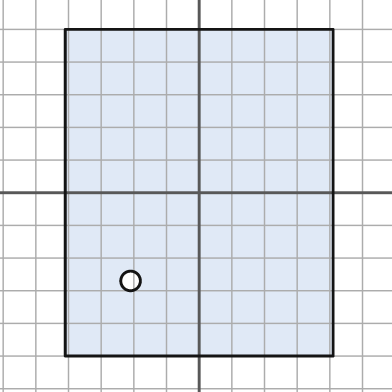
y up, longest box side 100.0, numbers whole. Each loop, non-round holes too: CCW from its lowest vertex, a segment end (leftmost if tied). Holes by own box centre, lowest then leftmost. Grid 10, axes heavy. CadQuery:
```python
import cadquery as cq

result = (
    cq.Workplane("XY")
    .moveTo(-41.0, -50.0)
    .lineTo(41.0, -50.0)
    .lineTo(41.0, 50.0)
    .lineTo(-41.0, 50.0)
    .close()
    .moveTo(-21.0, -27.0)
    .circle(3.0)
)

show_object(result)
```